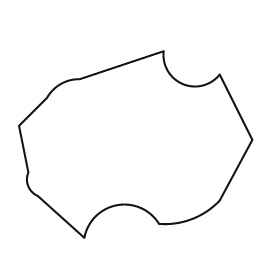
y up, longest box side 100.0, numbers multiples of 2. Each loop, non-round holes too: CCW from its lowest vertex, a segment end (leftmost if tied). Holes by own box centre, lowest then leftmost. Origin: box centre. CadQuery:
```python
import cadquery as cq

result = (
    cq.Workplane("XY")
    .moveTo(-22.0, -40.0)
    .threePointArc((-8.0, -26.0), (10.0, -34.0))
    .threePointArc((24.0, -32.0), (36.0, -24.0))
    .lineTo(50.0, 2.0)
    .lineTo(36.0, 30.0)
    .threePointArc((20.0, 26.0), (12.0, 40.0))
    .lineTo(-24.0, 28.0)
    .threePointArc((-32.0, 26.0), (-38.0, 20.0))
    .lineTo(-50.0, 8.0)
    .lineTo(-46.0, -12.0)
    .threePointArc((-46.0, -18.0), (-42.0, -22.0))
    .close()
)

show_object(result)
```